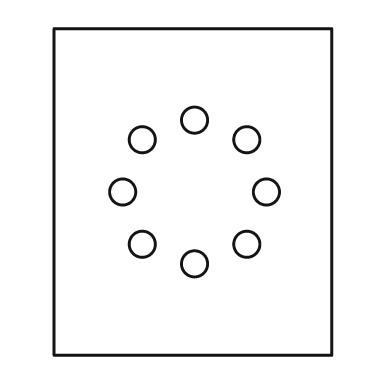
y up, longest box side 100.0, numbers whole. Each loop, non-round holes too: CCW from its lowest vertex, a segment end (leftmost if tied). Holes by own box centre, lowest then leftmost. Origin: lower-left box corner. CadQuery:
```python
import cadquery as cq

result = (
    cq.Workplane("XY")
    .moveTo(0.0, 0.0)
    .lineTo(85.0, 0.0)
    .lineTo(85.0, 100.0)
    .lineTo(0.0, 100.0)
    .close()
    .moveTo(43.0, 28.0)
    .circle(4.0)
    .moveTo(27.0, 34.0)
    .circle(4.0)
    .moveTo(59.0, 34.0)
    .circle(4.0)
    .moveTo(21.0, 50.0)
    .circle(4.0)
    .moveTo(65.0, 50.0)
    .circle(4.0)
    .moveTo(27.0, 66.0)
    .circle(4.0)
    .moveTo(59.0, 66.0)
    .circle(4.0)
    .moveTo(43.0, 72.0)
    .circle(4.0)
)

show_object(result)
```